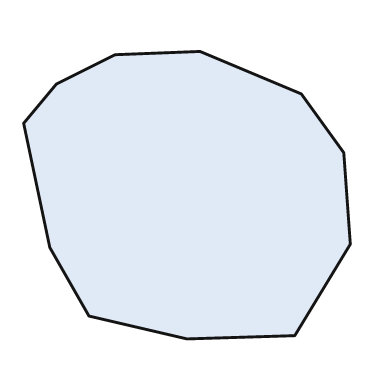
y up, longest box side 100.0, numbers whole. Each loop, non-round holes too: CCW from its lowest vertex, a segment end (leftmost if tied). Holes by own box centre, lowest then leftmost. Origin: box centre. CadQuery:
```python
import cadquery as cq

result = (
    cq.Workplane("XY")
    .moveTo(0.0, -44.0)
    .lineTo(33.0, -43.0)
    .lineTo(50.0, -15.0)
    .lineTo(48.0, 13.0)
    .lineTo(35.0, 31.0)
    .lineTo(4.0, 44.0)
    .lineTo(-22.0, 43.0)
    .lineTo(-40.0, 34.0)
    .lineTo(-50.0, 22.0)
    .lineTo(-42.0, -16.0)
    .lineTo(-30.0, -37.0)
    .close()
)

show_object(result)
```